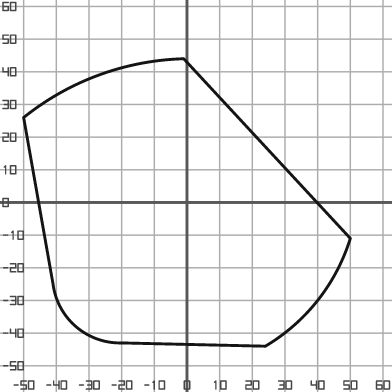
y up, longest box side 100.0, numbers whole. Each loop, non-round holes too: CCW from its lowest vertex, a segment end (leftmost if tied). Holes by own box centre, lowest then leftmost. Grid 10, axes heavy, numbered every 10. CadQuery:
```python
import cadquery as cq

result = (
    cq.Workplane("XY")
    .moveTo(24.0, -44.0)
    .threePointArc((40.0, -30.0), (50.0, -11.0))
    .lineTo(-1.0, 44.0)
    .threePointArc((-27.0, 39.0), (-50.0, 26.0))
    .lineTo(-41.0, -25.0)
    .threePointArc((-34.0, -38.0), (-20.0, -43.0))
    .close()
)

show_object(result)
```